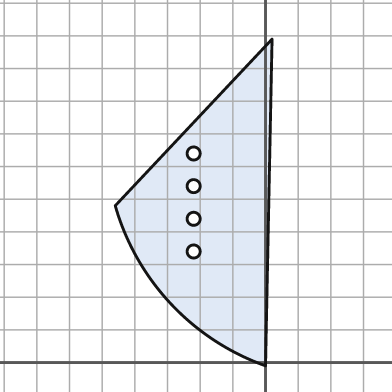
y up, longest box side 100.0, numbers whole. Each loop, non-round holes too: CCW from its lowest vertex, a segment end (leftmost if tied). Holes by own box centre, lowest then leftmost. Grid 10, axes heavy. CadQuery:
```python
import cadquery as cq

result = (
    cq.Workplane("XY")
    .moveTo(0.0, -1.0)
    .lineTo(2.0, 99.0)
    .lineTo(-46.0, 48.0)
    .threePointArc((-29.0, 18.0), (0.0, -1.0))
    .close()
    .moveTo(-22.0, 34.0)
    .circle(2.0)
    .moveTo(-22.0, 44.0)
    .circle(2.0)
    .moveTo(-22.0, 54.0)
    .circle(2.0)
    .moveTo(-22.0, 64.0)
    .circle(2.0)
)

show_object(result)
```